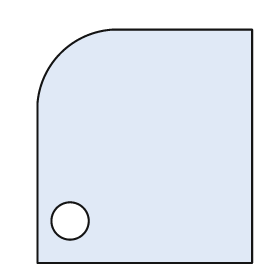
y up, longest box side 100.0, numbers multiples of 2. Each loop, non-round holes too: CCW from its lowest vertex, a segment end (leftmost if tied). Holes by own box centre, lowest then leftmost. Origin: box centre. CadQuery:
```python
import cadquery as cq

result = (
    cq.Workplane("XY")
    .moveTo(-46.0, -50.0)
    .lineTo(46.0, -50.0)
    .lineTo(46.0, 50.0)
    .lineTo(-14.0, 50.0)
    .threePointArc((-36.0, 40.0), (-46.0, 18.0))
    .close()
    .moveTo(-32.0, -32.0)
    .circle(8.0)
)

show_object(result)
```